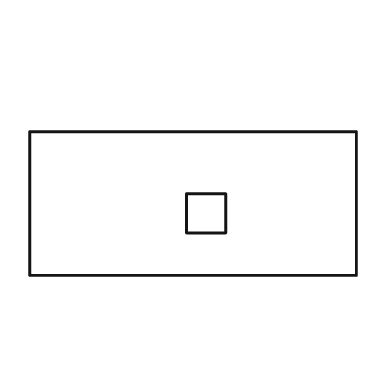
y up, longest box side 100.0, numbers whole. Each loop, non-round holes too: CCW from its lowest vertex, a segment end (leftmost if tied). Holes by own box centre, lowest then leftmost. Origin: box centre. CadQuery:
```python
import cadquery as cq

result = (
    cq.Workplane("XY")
    .moveTo(-50.0, -22.0)
    .lineTo(50.0, -22.0)
    .lineTo(50.0, 22.0)
    .lineTo(-50.0, 22.0)
    .close()
    .moveTo(-2.0, -9.0)
    .lineTo(10.0, -9.0)
    .lineTo(10.0, 3.0)
    .lineTo(-2.0, 3.0)
    .close()
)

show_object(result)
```